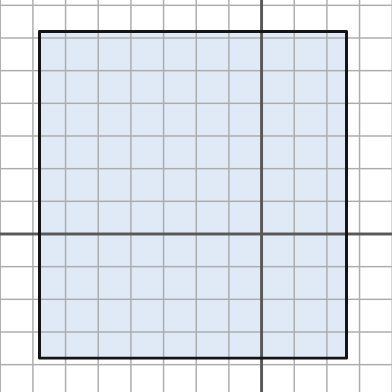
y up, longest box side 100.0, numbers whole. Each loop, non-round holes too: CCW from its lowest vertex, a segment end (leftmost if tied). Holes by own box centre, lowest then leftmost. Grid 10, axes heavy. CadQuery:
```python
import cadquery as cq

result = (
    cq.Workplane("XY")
    .moveTo(-68.0, -38.0)
    .lineTo(26.0, -38.0)
    .lineTo(26.0, 62.0)
    .lineTo(-68.0, 62.0)
    .close()
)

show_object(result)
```